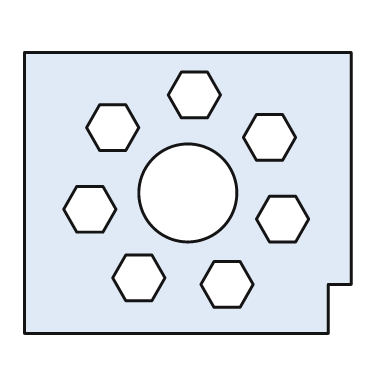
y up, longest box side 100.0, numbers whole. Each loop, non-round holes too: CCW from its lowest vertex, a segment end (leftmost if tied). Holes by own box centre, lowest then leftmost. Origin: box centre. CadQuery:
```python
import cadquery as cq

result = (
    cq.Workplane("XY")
    .moveTo(-50.0, -43.0)
    .lineTo(43.0, -43.0)
    .lineTo(43.0, -28.0)
    .lineTo(50.0, -28.0)
    .lineTo(50.0, 43.0)
    .lineTo(-50.0, 43.0)
    .close()
    .moveTo(8.0, -35.0)
    .lineTo(16.0, -35.0)
    .lineTo(20.0, -28.0)
    .lineTo(16.0, -21.0)
    .lineTo(8.0, -21.0)
    .lineTo(4.0, -28.0)
    .close()
    .moveTo(-19.0, -33.0)
    .lineTo(-11.0, -33.0)
    .lineTo(-7.0, -26.0)
    .lineTo(-11.0, -19.0)
    .lineTo(-19.0, -19.0)
    .lineTo(-23.0, -26.0)
    .close()
    .moveTo(25.0, -15.0)
    .lineTo(33.0, -15.0)
    .lineTo(37.0, -8.0)
    .lineTo(33.0, -1.0)
    .lineTo(25.0, -1.0)
    .lineTo(21.0, -8.0)
    .close()
    .moveTo(-34.0, -12.0)
    .lineTo(-26.0, -12.0)
    .lineTo(-22.0, -5.0)
    .lineTo(-26.0, 2.0)
    .lineTo(-34.0, 2.0)
    .lineTo(-38.0, -5.0)
    .close()
    .moveTo(0.0, 0.0)
    .circle(15.0)
    .moveTo(21.0, 10.0)
    .lineTo(29.0, 10.0)
    .lineTo(33.0, 17.0)
    .lineTo(29.0, 24.0)
    .lineTo(21.0, 24.0)
    .lineTo(17.0, 17.0)
    .close()
    .moveTo(-27.0, 13.0)
    .lineTo(-19.0, 13.0)
    .lineTo(-15.0, 20.0)
    .lineTo(-19.0, 27.0)
    .lineTo(-27.0, 27.0)
    .lineTo(-31.0, 20.0)
    .close()
    .moveTo(-2.0, 23.0)
    .lineTo(6.0, 23.0)
    .lineTo(10.0, 30.0)
    .lineTo(6.0, 37.0)
    .lineTo(-2.0, 37.0)
    .lineTo(-6.0, 30.0)
    .close()
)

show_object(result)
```